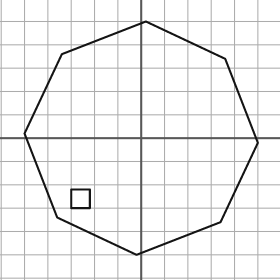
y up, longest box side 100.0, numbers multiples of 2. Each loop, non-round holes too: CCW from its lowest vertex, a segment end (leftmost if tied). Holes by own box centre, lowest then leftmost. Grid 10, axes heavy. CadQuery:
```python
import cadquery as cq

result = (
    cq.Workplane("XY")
    .moveTo(-2.0, -50.0)
    .lineTo(34.0, -36.0)
    .lineTo(50.0, -2.0)
    .lineTo(36.0, 34.0)
    .lineTo(2.0, 50.0)
    .lineTo(-34.0, 36.0)
    .lineTo(-50.0, 2.0)
    .lineTo(-36.0, -34.0)
    .close()
    .moveTo(-30.0, -30.0)
    .lineTo(-22.0, -30.0)
    .lineTo(-22.0, -22.0)
    .lineTo(-30.0, -22.0)
    .close()
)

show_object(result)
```